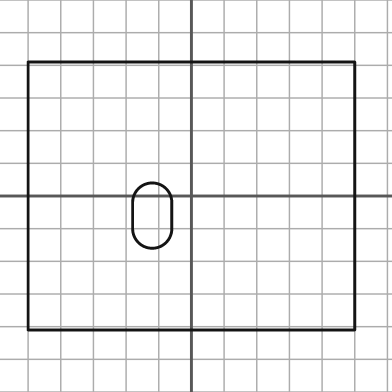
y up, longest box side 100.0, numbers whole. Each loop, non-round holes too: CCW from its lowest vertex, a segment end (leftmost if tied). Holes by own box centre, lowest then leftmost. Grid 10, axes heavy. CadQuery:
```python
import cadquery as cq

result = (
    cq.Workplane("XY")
    .moveTo(-50.0, -41.0)
    .lineTo(50.0, -41.0)
    .lineTo(50.0, 41.0)
    .lineTo(-50.0, 41.0)
    .close()
    .moveTo(-18.0, -10.0)
    .threePointArc((-12.0, -16.0), (-6.0, -10.0))
    .lineTo(-6.0, -2.0)
    .threePointArc((-12.0, 4.0), (-18.0, -2.0))
    .close()
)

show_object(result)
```